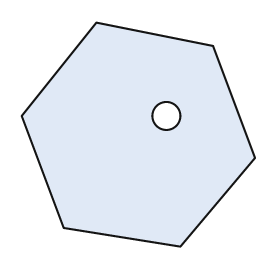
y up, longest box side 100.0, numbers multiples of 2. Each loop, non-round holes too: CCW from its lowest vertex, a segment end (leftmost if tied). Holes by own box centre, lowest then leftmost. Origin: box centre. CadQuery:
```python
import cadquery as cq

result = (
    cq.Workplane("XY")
    .moveTo(18.0, -48.0)
    .lineTo(50.0, -10.0)
    .lineTo(32.0, 38.0)
    .lineTo(-18.0, 48.0)
    .lineTo(-50.0, 8.0)
    .lineTo(-32.0, -40.0)
    .close()
    .moveTo(12.0, 8.0)
    .circle(6.0)
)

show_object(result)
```